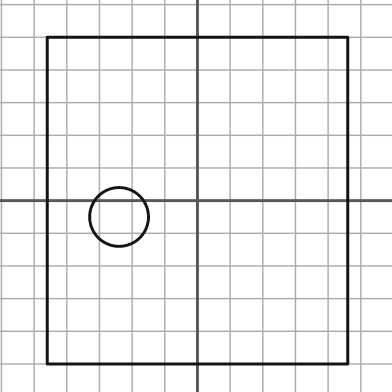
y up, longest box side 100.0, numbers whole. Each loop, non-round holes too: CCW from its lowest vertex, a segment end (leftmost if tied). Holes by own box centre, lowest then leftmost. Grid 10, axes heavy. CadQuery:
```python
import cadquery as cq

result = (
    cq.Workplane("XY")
    .moveTo(-46.0, -50.0)
    .lineTo(46.0, -50.0)
    .lineTo(46.0, 50.0)
    .lineTo(-46.0, 50.0)
    .close()
    .moveTo(-24.0, -5.0)
    .circle(9.0)
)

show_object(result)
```